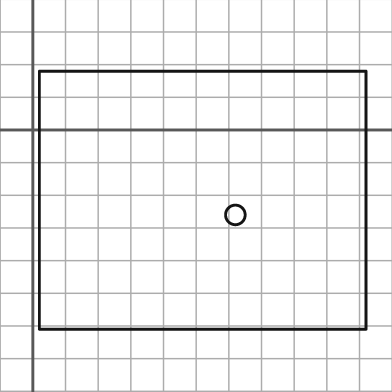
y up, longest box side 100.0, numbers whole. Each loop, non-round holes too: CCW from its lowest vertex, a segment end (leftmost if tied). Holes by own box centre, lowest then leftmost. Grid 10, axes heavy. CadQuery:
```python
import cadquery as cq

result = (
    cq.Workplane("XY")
    .moveTo(2.0, -61.0)
    .lineTo(102.0, -61.0)
    .lineTo(102.0, 18.0)
    .lineTo(2.0, 18.0)
    .close()
    .moveTo(62.0, -26.0)
    .circle(3.0)
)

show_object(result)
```